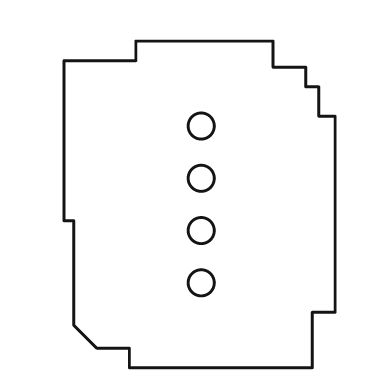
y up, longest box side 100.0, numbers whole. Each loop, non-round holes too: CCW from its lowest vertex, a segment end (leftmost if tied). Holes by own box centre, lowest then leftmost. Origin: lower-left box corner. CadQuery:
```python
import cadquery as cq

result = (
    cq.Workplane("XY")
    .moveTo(20.0, 0.0)
    .lineTo(76.0, 0.0)
    .lineTo(76.0, 17.0)
    .lineTo(83.0, 17.0)
    .lineTo(83.0, 77.0)
    .lineTo(78.0, 77.0)
    .lineTo(78.0, 86.0)
    .lineTo(74.0, 86.0)
    .lineTo(74.0, 92.0)
    .lineTo(64.0, 92.0)
    .lineTo(64.0, 100.0)
    .lineTo(22.0, 100.0)
    .lineTo(22.0, 94.0)
    .lineTo(0.0, 94.0)
    .lineTo(0.0, 45.0)
    .lineTo(3.0, 45.0)
    .lineTo(3.0, 13.0)
    .lineTo(10.0, 6.0)
    .lineTo(20.0, 6.0)
    .close()
    .moveTo(42.0, 26.0)
    .circle(4.0)
    .moveTo(42.0, 42.0)
    .circle(4.0)
    .moveTo(42.0, 58.0)
    .circle(4.0)
    .moveTo(42.0, 74.0)
    .circle(4.0)
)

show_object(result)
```